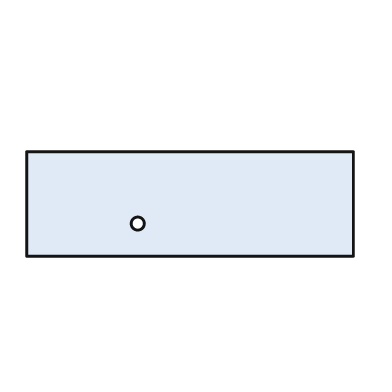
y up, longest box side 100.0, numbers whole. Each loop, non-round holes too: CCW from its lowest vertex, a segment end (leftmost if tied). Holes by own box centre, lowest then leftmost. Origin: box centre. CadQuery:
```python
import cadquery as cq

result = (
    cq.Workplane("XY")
    .moveTo(-50.0, -16.0)
    .lineTo(50.0, -16.0)
    .lineTo(50.0, 16.0)
    .lineTo(-50.0, 16.0)
    .close()
    .moveTo(-16.0, -6.0)
    .circle(2.0)
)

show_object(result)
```